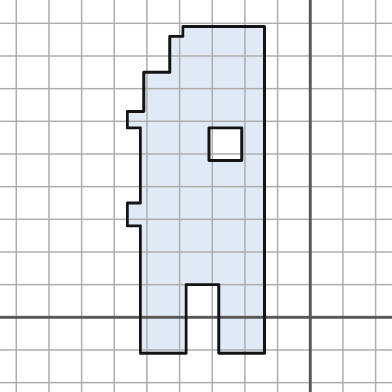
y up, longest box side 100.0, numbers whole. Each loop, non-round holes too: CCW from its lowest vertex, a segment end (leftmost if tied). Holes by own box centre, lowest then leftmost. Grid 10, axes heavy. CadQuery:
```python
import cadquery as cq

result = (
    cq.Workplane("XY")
    .moveTo(-52.0, -11.0)
    .lineTo(-38.0, -11.0)
    .lineTo(-38.0, 10.0)
    .lineTo(-28.0, 10.0)
    .lineTo(-28.0, -11.0)
    .lineTo(-14.0, -11.0)
    .lineTo(-14.0, 89.0)
    .lineTo(-39.0, 89.0)
    .lineTo(-39.0, 86.0)
    .lineTo(-43.0, 86.0)
    .lineTo(-43.0, 75.0)
    .lineTo(-51.0, 75.0)
    .lineTo(-51.0, 63.0)
    .lineTo(-56.0, 63.0)
    .lineTo(-56.0, 58.0)
    .lineTo(-52.0, 58.0)
    .lineTo(-52.0, 35.0)
    .lineTo(-56.0, 35.0)
    .lineTo(-56.0, 28.0)
    .lineTo(-52.0, 28.0)
    .close()
    .moveTo(-31.0, 48.0)
    .lineTo(-21.0, 48.0)
    .lineTo(-21.0, 58.0)
    .lineTo(-31.0, 58.0)
    .close()
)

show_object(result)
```